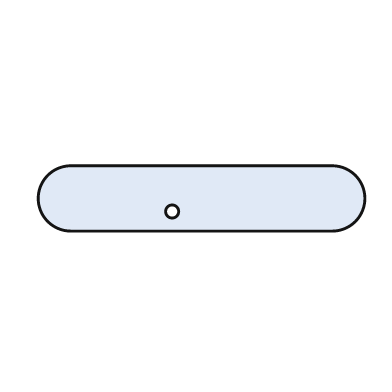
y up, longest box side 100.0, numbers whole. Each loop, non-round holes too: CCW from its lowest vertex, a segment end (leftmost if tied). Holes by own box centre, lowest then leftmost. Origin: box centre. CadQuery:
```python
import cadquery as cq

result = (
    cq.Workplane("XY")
    .moveTo(-40.0, -10.0)
    .lineTo(40.0, -10.0)
    .threePointArc((50.0, 0.0), (40.0, 10.0))
    .lineTo(-40.0, 10.0)
    .threePointArc((-50.0, 0.0), (-40.0, -10.0))
    .close()
    .moveTo(-9.0, -4.0)
    .circle(2.0)
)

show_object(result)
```